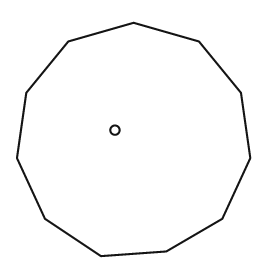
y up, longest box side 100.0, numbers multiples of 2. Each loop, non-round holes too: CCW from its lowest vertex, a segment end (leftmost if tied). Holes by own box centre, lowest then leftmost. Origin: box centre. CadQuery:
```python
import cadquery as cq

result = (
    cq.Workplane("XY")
    .moveTo(-14.0, -50.0)
    .lineTo(14.0, -48.0)
    .lineTo(38.0, -34.0)
    .lineTo(50.0, -8.0)
    .lineTo(46.0, 20.0)
    .lineTo(28.0, 42.0)
    .lineTo(0.0, 50.0)
    .lineTo(-28.0, 42.0)
    .lineTo(-46.0, 20.0)
    .lineTo(-50.0, -8.0)
    .lineTo(-38.0, -34.0)
    .close()
    .moveTo(-8.0, 4.0)
    .circle(2.0)
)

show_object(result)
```